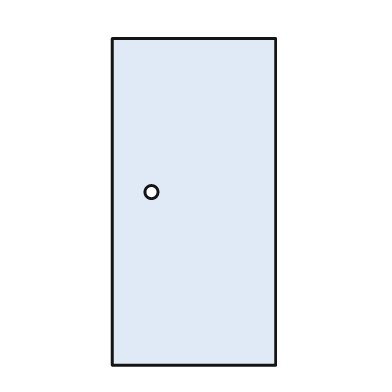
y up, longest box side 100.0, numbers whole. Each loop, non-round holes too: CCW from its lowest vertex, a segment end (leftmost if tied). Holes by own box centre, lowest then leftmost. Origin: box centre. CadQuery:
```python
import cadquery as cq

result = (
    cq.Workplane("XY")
    .moveTo(-25.0, -50.0)
    .lineTo(25.0, -50.0)
    .lineTo(25.0, 50.0)
    .lineTo(-25.0, 50.0)
    .close()
    .moveTo(-13.0, 3.0)
    .circle(2.0)
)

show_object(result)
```